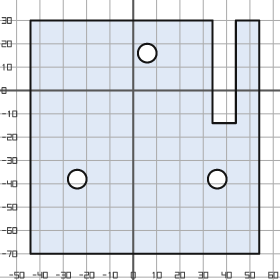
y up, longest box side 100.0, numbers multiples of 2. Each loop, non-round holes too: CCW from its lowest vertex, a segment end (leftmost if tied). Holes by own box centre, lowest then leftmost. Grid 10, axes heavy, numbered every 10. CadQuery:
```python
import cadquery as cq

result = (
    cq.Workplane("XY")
    .moveTo(-44.0, -70.0)
    .lineTo(54.0, -70.0)
    .lineTo(54.0, 30.0)
    .lineTo(44.0, 30.0)
    .lineTo(44.0, -14.0)
    .lineTo(34.0, -14.0)
    .lineTo(34.0, 30.0)
    .lineTo(-44.0, 30.0)
    .close()
    .moveTo(-24.0, -38.0)
    .circle(4.0)
    .moveTo(36.0, -38.0)
    .circle(4.0)
    .moveTo(6.0, 16.0)
    .circle(4.0)
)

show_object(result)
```